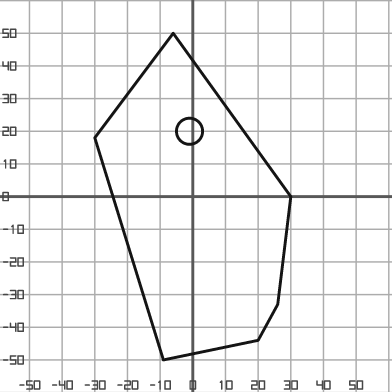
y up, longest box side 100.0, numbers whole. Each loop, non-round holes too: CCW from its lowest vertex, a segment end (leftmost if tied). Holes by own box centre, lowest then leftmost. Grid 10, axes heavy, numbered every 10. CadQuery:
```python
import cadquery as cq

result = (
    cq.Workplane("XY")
    .moveTo(-9.0, -50.0)
    .lineTo(20.0, -44.0)
    .lineTo(26.0, -33.0)
    .lineTo(30.0, 0.0)
    .lineTo(-6.0, 50.0)
    .lineTo(-30.0, 18.0)
    .close()
    .moveTo(-1.0, 20.0)
    .circle(4.0)
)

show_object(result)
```